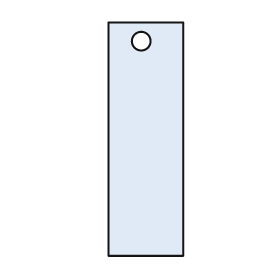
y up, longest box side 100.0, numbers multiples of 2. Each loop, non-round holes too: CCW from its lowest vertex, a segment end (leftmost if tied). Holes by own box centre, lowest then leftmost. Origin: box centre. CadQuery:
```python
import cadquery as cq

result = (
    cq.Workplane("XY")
    .moveTo(-16.0, -50.0)
    .lineTo(16.0, -50.0)
    .lineTo(16.0, 50.0)
    .lineTo(-16.0, 50.0)
    .close()
    .moveTo(-2.0, 42.0)
    .circle(4.0)
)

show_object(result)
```